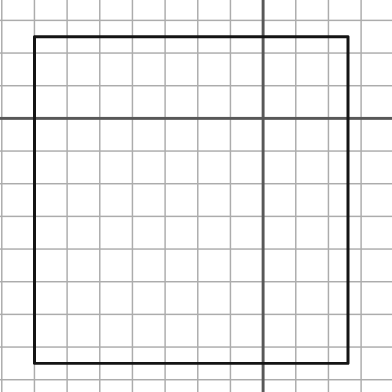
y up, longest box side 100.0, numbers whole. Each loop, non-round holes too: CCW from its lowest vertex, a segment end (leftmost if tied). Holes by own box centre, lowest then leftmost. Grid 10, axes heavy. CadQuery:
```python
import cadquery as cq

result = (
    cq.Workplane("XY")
    .moveTo(-70.0, -75.0)
    .lineTo(26.0, -75.0)
    .lineTo(26.0, 25.0)
    .lineTo(-70.0, 25.0)
    .close()
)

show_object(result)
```